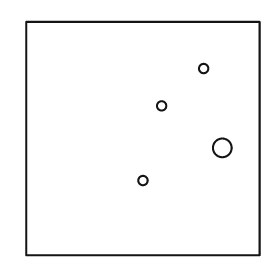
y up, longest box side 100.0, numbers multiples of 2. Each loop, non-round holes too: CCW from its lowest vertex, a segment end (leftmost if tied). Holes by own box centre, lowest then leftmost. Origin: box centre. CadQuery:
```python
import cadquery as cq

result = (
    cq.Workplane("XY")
    .moveTo(-50.0, -50.0)
    .lineTo(50.0, -50.0)
    .lineTo(50.0, 50.0)
    .lineTo(-50.0, 50.0)
    .close()
    .moveTo(0.0, -18.0)
    .circle(2.0)
    .moveTo(34.0, -4.0)
    .circle(4.0)
    .moveTo(8.0, 14.0)
    .circle(2.0)
    .moveTo(26.0, 30.0)
    .circle(2.0)
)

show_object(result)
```